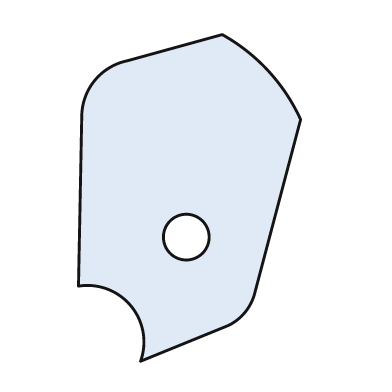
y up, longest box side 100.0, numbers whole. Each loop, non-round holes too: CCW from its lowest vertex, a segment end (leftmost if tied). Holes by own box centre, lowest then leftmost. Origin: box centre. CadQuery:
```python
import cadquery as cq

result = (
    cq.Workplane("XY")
    .moveTo(-15.0, -50.0)
    .lineTo(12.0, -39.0)
    .threePointArc((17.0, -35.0), (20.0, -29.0))
    .lineTo(34.0, 24.0)
    .threePointArc((24.0, 39.0), (10.0, 50.0))
    .lineTo(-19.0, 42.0)
    .threePointArc((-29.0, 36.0), (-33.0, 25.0))
    .lineTo(-34.0, -27.0)
    .threePointArc((-18.0, -33.0), (-15.0, -50.0))
    .close()
    .moveTo(-1.0, -12.0)
    .circle(7.0)
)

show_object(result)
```